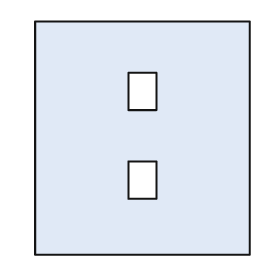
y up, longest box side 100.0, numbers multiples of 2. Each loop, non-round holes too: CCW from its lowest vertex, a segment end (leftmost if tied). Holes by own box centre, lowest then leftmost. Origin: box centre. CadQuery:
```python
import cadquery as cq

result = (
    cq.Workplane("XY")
    .moveTo(-46.0, -50.0)
    .lineTo(46.0, -50.0)
    .lineTo(46.0, 50.0)
    .lineTo(-46.0, 50.0)
    .close()
    .moveTo(-6.0, -26.0)
    .lineTo(6.0, -26.0)
    .lineTo(6.0, -10.0)
    .lineTo(-6.0, -10.0)
    .close()
    .moveTo(-6.0, 12.0)
    .lineTo(6.0, 12.0)
    .lineTo(6.0, 28.0)
    .lineTo(-6.0, 28.0)
    .close()
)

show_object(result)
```